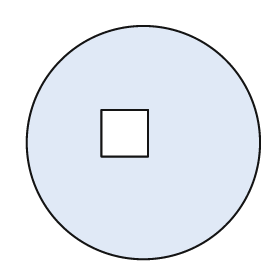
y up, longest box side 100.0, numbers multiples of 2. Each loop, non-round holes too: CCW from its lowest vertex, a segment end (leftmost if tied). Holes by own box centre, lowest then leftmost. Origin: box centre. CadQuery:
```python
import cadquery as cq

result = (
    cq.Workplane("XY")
    .moveTo(0.0, 0.0)
    .circle(50.0)
    .moveTo(-18.0, -6.0)
    .lineTo(2.0, -6.0)
    .lineTo(2.0, 14.0)
    .lineTo(-18.0, 14.0)
    .close()
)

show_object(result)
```